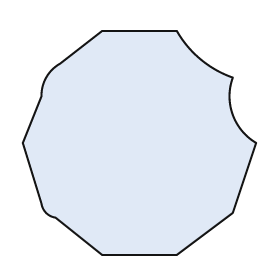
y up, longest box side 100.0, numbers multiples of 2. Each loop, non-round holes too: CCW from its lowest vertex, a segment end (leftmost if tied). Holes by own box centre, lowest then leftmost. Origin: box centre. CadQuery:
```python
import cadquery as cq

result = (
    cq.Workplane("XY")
    .moveTo(-16.0, -48.0)
    .lineTo(16.0, -48.0)
    .lineTo(40.0, -30.0)
    .lineTo(50.0, 0.0)
    .threePointArc((40.0, 12.0), (40.0, 28.0))
    .threePointArc((26.0, 36.0), (16.0, 48.0))
    .lineTo(-16.0, 48.0)
    .lineTo(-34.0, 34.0)
    .threePointArc((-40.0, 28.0), (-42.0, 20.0))
    .lineTo(-50.0, 0.0)
    .lineTo(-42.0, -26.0)
    .threePointArc((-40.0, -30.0), (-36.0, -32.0))
    .close()
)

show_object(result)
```